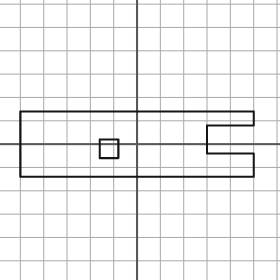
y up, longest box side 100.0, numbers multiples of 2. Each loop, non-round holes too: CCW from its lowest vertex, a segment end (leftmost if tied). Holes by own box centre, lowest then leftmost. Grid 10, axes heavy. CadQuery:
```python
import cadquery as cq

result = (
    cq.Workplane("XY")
    .moveTo(-50.0, -14.0)
    .lineTo(50.0, -14.0)
    .lineTo(50.0, -4.0)
    .lineTo(30.0, -4.0)
    .lineTo(30.0, 8.0)
    .lineTo(50.0, 8.0)
    .lineTo(50.0, 14.0)
    .lineTo(-50.0, 14.0)
    .close()
    .moveTo(-16.0, -6.0)
    .lineTo(-8.0, -6.0)
    .lineTo(-8.0, 2.0)
    .lineTo(-16.0, 2.0)
    .close()
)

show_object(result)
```